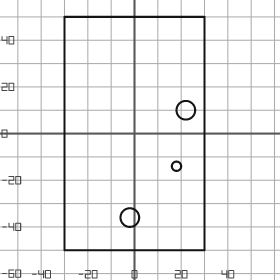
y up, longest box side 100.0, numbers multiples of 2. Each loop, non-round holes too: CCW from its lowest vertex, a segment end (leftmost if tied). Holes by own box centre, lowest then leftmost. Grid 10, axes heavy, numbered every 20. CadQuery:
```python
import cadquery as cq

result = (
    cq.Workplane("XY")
    .moveTo(-30.0, -50.0)
    .lineTo(30.0, -50.0)
    .lineTo(30.0, 50.0)
    .lineTo(-30.0, 50.0)
    .close()
    .moveTo(-2.0, -36.0)
    .circle(4.0)
    .moveTo(18.0, -14.0)
    .circle(2.0)
    .moveTo(22.0, 10.0)
    .circle(4.0)
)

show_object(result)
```